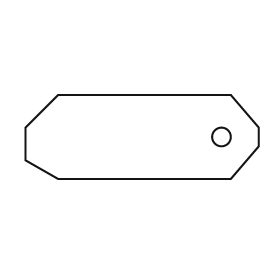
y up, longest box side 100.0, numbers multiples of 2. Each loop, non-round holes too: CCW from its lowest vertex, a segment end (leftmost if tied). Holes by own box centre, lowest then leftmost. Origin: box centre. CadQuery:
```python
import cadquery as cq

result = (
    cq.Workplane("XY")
    .moveTo(-36.0, -18.0)
    .lineTo(38.0, -18.0)
    .lineTo(50.0, -4.0)
    .lineTo(50.0, 4.0)
    .lineTo(38.0, 18.0)
    .lineTo(-36.0, 18.0)
    .lineTo(-50.0, 4.0)
    .lineTo(-50.0, -10.0)
    .close()
    .moveTo(34.0, 0.0)
    .circle(4.0)
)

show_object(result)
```